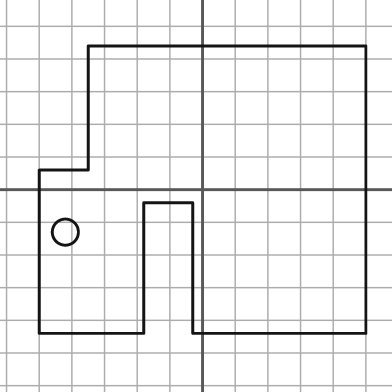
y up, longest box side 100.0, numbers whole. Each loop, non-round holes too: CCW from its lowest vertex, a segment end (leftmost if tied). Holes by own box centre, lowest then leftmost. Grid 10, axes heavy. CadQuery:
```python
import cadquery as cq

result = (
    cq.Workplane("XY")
    .moveTo(-50.0, -44.0)
    .lineTo(-18.0, -44.0)
    .lineTo(-18.0, -4.0)
    .lineTo(-3.0, -4.0)
    .lineTo(-3.0, -44.0)
    .lineTo(50.0, -44.0)
    .lineTo(50.0, 44.0)
    .lineTo(-35.0, 44.0)
    .lineTo(-35.0, 6.0)
    .lineTo(-50.0, 6.0)
    .close()
    .moveTo(-42.0, -13.0)
    .circle(4.0)
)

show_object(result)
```